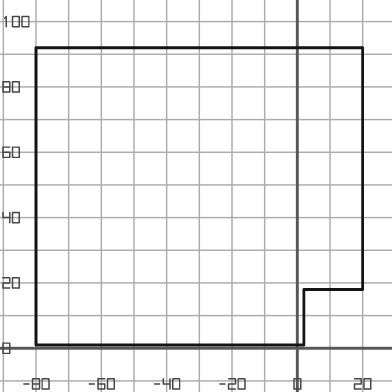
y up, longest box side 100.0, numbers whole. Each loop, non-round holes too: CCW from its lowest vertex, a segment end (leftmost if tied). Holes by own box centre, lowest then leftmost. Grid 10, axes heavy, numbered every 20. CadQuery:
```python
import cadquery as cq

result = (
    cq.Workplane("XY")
    .moveTo(-80.0, 1.0)
    .lineTo(2.0, 1.0)
    .lineTo(2.0, 18.0)
    .lineTo(20.0, 18.0)
    .lineTo(20.0, 92.0)
    .lineTo(-80.0, 92.0)
    .close()
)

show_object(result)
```